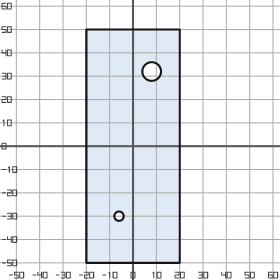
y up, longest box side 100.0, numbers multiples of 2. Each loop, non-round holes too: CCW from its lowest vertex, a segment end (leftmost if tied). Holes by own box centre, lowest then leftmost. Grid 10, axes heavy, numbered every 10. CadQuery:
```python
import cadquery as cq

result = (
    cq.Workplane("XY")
    .moveTo(-20.0, -50.0)
    .lineTo(20.0, -50.0)
    .lineTo(20.0, 50.0)
    .lineTo(-20.0, 50.0)
    .close()
    .moveTo(-6.0, -30.0)
    .circle(2.0)
    .moveTo(8.0, 32.0)
    .circle(4.0)
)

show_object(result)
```